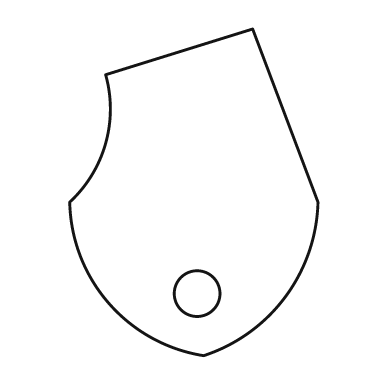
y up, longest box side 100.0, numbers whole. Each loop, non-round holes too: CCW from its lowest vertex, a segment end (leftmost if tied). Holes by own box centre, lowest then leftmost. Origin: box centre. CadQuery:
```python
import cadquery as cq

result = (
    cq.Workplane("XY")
    .moveTo(3.0, -50.0)
    .threePointArc((28.0, -32.0), (38.0, -3.0))
    .lineTo(18.0, 50.0)
    .lineTo(-27.0, 36.0)
    .threePointArc((-27.0, 15.0), (-38.0, -3.0))
    .threePointArc((-26.0, -34.0), (3.0, -50.0))
    .close()
    .moveTo(1.0, -31.0)
    .circle(7.0)
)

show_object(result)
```